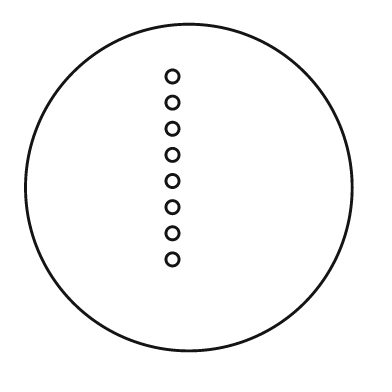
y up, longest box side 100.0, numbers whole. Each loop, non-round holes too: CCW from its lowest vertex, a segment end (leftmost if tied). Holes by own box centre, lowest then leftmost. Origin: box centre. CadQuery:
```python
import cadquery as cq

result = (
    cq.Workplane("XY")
    .moveTo(0.0, 0.0)
    .circle(50.0)
    .moveTo(-5.0, -22.0)
    .circle(2.0)
    .moveTo(-5.0, -14.0)
    .circle(2.0)
    .moveTo(-5.0, -6.0)
    .circle(2.0)
    .moveTo(-5.0, 2.0)
    .circle(2.0)
    .moveTo(-5.0, 10.0)
    .circle(2.0)
    .moveTo(-5.0, 18.0)
    .circle(2.0)
    .moveTo(-5.0, 26.0)
    .circle(2.0)
    .moveTo(-5.0, 34.0)
    .circle(2.0)
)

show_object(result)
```